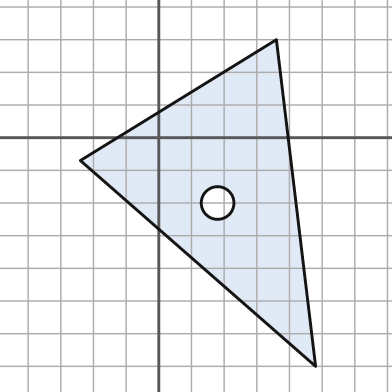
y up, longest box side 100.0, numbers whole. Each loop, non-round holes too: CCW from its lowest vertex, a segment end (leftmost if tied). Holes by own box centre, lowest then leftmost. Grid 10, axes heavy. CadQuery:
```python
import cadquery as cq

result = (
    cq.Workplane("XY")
    .moveTo(48.0, -70.0)
    .lineTo(36.0, 30.0)
    .lineTo(-24.0, -7.0)
    .close()
    .moveTo(18.0, -20.0)
    .circle(5.0)
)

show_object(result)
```